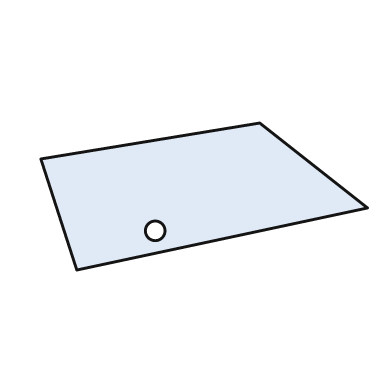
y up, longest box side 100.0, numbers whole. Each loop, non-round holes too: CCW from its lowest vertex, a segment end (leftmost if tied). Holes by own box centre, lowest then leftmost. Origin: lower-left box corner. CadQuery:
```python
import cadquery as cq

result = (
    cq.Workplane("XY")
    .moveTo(11.0, 0.0)
    .lineTo(100.0, 19.0)
    .lineTo(67.0, 45.0)
    .lineTo(0.0, 34.0)
    .close()
    .moveTo(35.0, 12.0)
    .circle(3.0)
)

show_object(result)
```